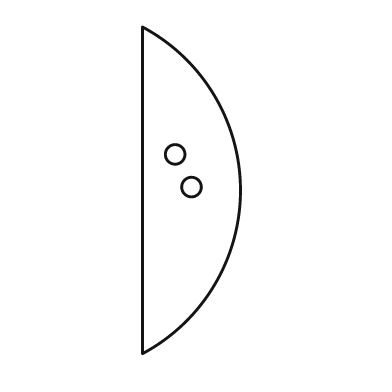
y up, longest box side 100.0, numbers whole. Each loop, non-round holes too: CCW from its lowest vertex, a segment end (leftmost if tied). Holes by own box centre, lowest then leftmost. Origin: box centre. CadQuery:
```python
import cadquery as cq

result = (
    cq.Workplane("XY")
    .moveTo(-15.0, -50.0)
    .threePointArc((15.0, 0.0), (-15.0, 50.0))
    .close()
    .moveTo(0.0, 1.0)
    .circle(3.0)
    .moveTo(-5.0, 11.0)
    .circle(3.0)
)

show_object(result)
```